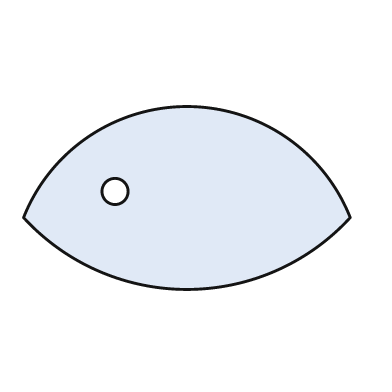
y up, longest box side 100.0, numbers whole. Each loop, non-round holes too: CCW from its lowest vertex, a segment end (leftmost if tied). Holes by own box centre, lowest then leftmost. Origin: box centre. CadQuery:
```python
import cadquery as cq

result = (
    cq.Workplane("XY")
    .moveTo(-50.0, -6.0)
    .threePointArc((0.0, -28.0), (50.0, -6.0))
    .threePointArc((0.0, 28.0), (-50.0, -6.0))
    .close()
    .moveTo(-22.0, 2.0)
    .circle(4.0)
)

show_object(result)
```